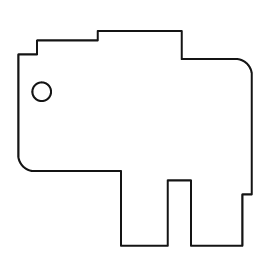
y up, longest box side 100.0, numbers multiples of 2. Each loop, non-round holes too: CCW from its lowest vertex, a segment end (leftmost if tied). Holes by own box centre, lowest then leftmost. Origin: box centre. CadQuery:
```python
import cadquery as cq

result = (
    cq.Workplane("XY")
    .moveTo(-6.0, -46.0)
    .lineTo(14.0, -46.0)
    .lineTo(14.0, -18.0)
    .lineTo(24.0, -18.0)
    .lineTo(24.0, -46.0)
    .lineTo(46.0, -46.0)
    .lineTo(46.0, -24.0)
    .lineTo(50.0, -24.0)
    .lineTo(50.0, 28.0)
    .threePointArc((48.0, 32.0), (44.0, 34.0))
    .lineTo(20.0, 34.0)
    .lineTo(20.0, 46.0)
    .lineTo(-16.0, 46.0)
    .lineTo(-16.0, 42.0)
    .lineTo(-42.0, 42.0)
    .lineTo(-42.0, 36.0)
    .lineTo(-50.0, 36.0)
    .lineTo(-50.0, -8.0)
    .threePointArc((-48.0, -12.0), (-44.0, -14.0))
    .lineTo(-6.0, -14.0)
    .close()
    .moveTo(-40.0, 20.0)
    .circle(4.0)
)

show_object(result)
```